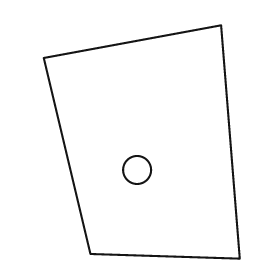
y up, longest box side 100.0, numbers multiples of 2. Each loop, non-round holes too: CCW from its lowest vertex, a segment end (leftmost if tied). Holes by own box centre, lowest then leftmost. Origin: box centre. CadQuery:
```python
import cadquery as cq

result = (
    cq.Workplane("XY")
    .moveTo(42.0, -50.0)
    .lineTo(34.0, 50.0)
    .lineTo(-42.0, 36.0)
    .lineTo(-22.0, -48.0)
    .close()
    .moveTo(-2.0, -12.0)
    .circle(6.0)
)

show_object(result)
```